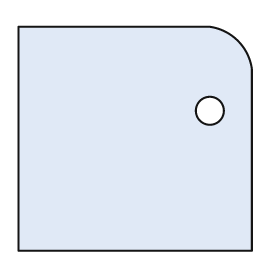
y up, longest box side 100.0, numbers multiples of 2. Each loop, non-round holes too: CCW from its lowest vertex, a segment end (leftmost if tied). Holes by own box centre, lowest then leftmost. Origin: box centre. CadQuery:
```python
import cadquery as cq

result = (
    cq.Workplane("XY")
    .moveTo(-50.0, -48.0)
    .lineTo(50.0, -48.0)
    .lineTo(50.0, 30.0)
    .threePointArc((44.0, 42.0), (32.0, 48.0))
    .lineTo(-50.0, 48.0)
    .close()
    .moveTo(32.0, 12.0)
    .circle(6.0)
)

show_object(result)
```